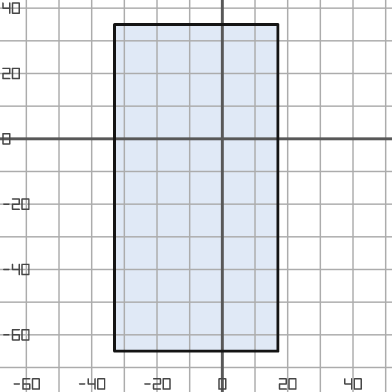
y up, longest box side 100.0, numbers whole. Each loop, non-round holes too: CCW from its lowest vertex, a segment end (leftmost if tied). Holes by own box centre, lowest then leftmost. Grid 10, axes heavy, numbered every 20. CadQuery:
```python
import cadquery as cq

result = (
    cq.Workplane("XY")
    .moveTo(-33.0, -65.0)
    .lineTo(17.0, -65.0)
    .lineTo(17.0, 35.0)
    .lineTo(-33.0, 35.0)
    .close()
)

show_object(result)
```